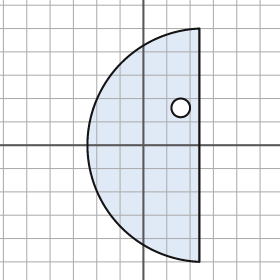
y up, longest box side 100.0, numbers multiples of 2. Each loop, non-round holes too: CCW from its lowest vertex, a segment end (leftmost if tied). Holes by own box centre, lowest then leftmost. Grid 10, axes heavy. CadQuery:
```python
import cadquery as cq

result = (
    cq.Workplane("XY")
    .moveTo(24.0, -50.0)
    .lineTo(24.0, 50.0)
    .threePointArc((-24.0, 0.0), (24.0, -50.0))
    .close()
    .moveTo(16.0, 16.0)
    .circle(4.0)
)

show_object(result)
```